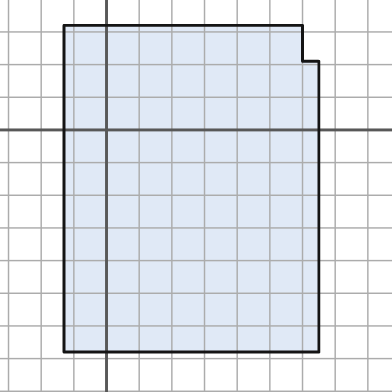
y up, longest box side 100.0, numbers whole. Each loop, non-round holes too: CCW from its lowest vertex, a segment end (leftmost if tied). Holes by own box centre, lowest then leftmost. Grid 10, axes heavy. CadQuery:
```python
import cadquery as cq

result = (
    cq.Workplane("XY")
    .moveTo(-13.0, -68.0)
    .lineTo(65.0, -68.0)
    .lineTo(65.0, 21.0)
    .lineTo(60.0, 21.0)
    .lineTo(60.0, 32.0)
    .lineTo(-13.0, 32.0)
    .close()
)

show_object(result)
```